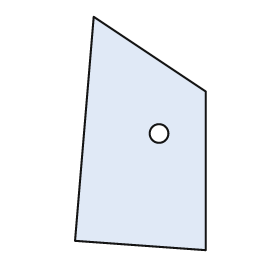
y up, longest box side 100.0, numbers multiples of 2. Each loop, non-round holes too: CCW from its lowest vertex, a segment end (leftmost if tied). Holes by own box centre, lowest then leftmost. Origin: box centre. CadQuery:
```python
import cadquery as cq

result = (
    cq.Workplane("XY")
    .moveTo(28.0, -50.0)
    .lineTo(28.0, 18.0)
    .lineTo(-20.0, 50.0)
    .lineTo(-28.0, -46.0)
    .close()
    .moveTo(8.0, 0.0)
    .circle(4.0)
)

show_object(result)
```